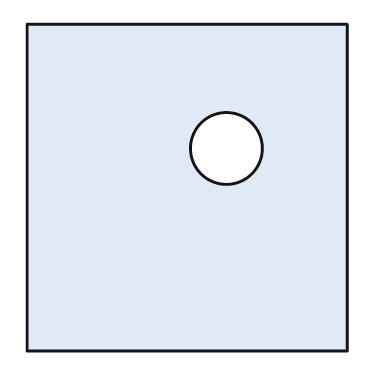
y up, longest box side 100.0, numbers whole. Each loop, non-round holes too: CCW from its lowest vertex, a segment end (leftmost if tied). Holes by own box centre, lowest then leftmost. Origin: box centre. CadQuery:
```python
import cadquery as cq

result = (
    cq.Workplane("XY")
    .moveTo(-49.0, -50.0)
    .lineTo(49.0, -50.0)
    .lineTo(49.0, 50.0)
    .lineTo(-49.0, 50.0)
    .close()
    .moveTo(12.0, 12.0)
    .circle(11.0)
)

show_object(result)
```